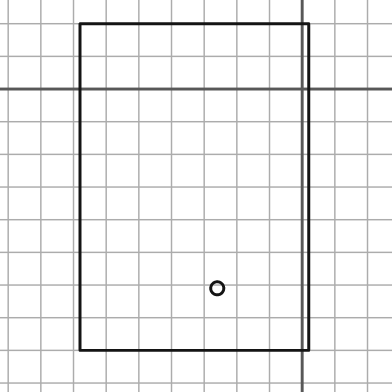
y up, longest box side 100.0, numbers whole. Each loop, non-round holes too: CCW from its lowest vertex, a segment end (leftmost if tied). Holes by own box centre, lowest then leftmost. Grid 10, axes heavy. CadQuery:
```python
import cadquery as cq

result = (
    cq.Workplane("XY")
    .moveTo(-68.0, -80.0)
    .lineTo(2.0, -80.0)
    .lineTo(2.0, 20.0)
    .lineTo(-68.0, 20.0)
    .close()
    .moveTo(-26.0, -61.0)
    .circle(2.0)
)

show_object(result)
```